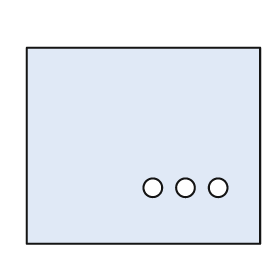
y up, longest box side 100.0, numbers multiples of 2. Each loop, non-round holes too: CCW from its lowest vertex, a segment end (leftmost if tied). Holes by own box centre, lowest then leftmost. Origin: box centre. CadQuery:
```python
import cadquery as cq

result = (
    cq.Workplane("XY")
    .moveTo(-50.0, -42.0)
    .lineTo(50.0, -42.0)
    .lineTo(50.0, 42.0)
    .lineTo(-50.0, 42.0)
    .close()
    .moveTo(4.0, -18.0)
    .circle(4.0)
    .moveTo(18.0, -18.0)
    .circle(4.0)
    .moveTo(32.0, -18.0)
    .circle(4.0)
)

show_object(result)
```